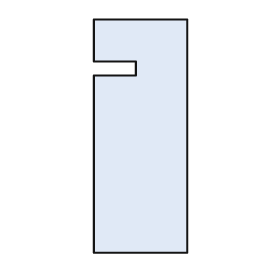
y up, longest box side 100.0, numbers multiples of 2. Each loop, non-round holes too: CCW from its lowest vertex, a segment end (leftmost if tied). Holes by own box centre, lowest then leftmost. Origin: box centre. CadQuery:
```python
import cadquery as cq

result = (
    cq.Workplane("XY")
    .moveTo(-20.0, -50.0)
    .lineTo(20.0, -50.0)
    .lineTo(20.0, 50.0)
    .lineTo(-20.0, 50.0)
    .lineTo(-20.0, 32.0)
    .lineTo(-2.0, 32.0)
    .lineTo(-2.0, 26.0)
    .lineTo(-20.0, 26.0)
    .close()
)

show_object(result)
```